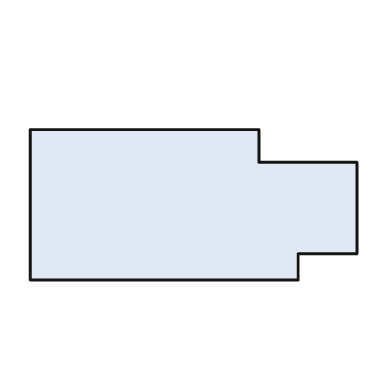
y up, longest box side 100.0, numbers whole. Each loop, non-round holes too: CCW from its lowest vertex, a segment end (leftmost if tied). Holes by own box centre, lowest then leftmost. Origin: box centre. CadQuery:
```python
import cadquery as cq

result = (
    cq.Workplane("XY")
    .moveTo(-50.0, -23.0)
    .lineTo(32.0, -23.0)
    .lineTo(32.0, -15.0)
    .lineTo(50.0, -15.0)
    .lineTo(50.0, 13.0)
    .lineTo(20.0, 13.0)
    .lineTo(20.0, 23.0)
    .lineTo(-50.0, 23.0)
    .close()
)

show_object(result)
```